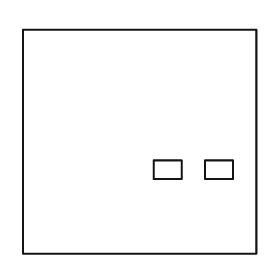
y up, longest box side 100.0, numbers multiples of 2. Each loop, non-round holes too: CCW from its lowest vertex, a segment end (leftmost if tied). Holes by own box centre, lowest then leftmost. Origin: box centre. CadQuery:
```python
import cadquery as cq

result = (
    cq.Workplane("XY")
    .moveTo(-50.0, -48.0)
    .lineTo(50.0, -48.0)
    .lineTo(50.0, 48.0)
    .lineTo(-50.0, 48.0)
    .close()
    .moveTo(6.0, -16.0)
    .lineTo(18.0, -16.0)
    .lineTo(18.0, -8.0)
    .lineTo(6.0, -8.0)
    .close()
    .moveTo(28.0, -16.0)
    .lineTo(40.0, -16.0)
    .lineTo(40.0, -8.0)
    .lineTo(28.0, -8.0)
    .close()
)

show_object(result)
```